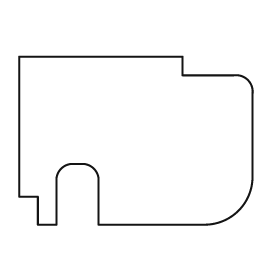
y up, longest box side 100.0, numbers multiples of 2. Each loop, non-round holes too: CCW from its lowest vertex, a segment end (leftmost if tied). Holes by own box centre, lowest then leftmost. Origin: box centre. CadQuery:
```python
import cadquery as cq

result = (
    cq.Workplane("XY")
    .moveTo(-42.0, -36.0)
    .lineTo(-34.0, -36.0)
    .lineTo(-34.0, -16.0)
    .threePointArc((-32.0, -12.0), (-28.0, -10.0))
    .lineTo(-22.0, -10.0)
    .threePointArc((-18.0, -12.0), (-16.0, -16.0))
    .lineTo(-16.0, -36.0)
    .lineTo(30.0, -36.0)
    .threePointArc((44.0, -30.0), (50.0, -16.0))
    .lineTo(50.0, 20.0)
    .threePointArc((48.0, 26.0), (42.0, 28.0))
    .lineTo(20.0, 28.0)
    .lineTo(20.0, 36.0)
    .lineTo(-50.0, 36.0)
    .lineTo(-50.0, -24.0)
    .lineTo(-42.0, -24.0)
    .close()
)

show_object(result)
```